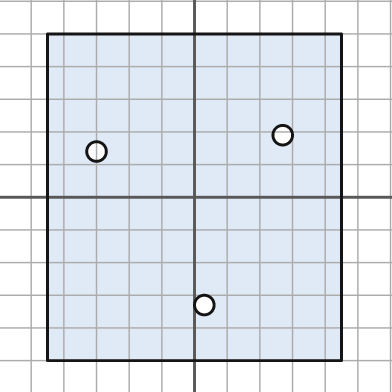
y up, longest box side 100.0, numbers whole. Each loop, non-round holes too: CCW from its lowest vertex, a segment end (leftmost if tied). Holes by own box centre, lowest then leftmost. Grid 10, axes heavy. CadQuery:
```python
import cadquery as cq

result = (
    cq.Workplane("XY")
    .moveTo(-45.0, -50.0)
    .lineTo(45.0, -50.0)
    .lineTo(45.0, 50.0)
    .lineTo(-45.0, 50.0)
    .close()
    .moveTo(3.0, -33.0)
    .circle(3.0)
    .moveTo(-30.0, 14.0)
    .circle(3.0)
    .moveTo(27.0, 19.0)
    .circle(3.0)
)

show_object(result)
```